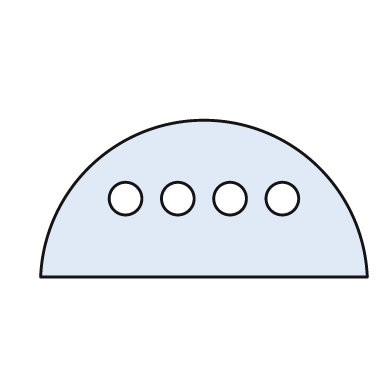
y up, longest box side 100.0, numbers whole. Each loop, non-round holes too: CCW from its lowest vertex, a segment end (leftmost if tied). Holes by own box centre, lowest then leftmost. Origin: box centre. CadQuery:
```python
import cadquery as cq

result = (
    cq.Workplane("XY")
    .moveTo(-50.0, -24.0)
    .lineTo(50.0, -24.0)
    .threePointArc((0.0, 24.0), (-50.0, -24.0))
    .close()
    .moveTo(-24.0, 0.0)
    .circle(5.0)
    .moveTo(-8.0, 0.0)
    .circle(5.0)
    .moveTo(8.0, 0.0)
    .circle(5.0)
    .moveTo(24.0, 0.0)
    .circle(5.0)
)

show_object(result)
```